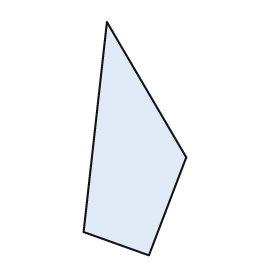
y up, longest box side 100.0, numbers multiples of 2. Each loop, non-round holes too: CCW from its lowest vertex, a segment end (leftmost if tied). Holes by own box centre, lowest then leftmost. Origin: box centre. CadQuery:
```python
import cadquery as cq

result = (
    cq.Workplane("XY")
    .moveTo(6.0, -50.0)
    .lineTo(22.0, -8.0)
    .lineTo(-12.0, 50.0)
    .lineTo(-22.0, -40.0)
    .close()
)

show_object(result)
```